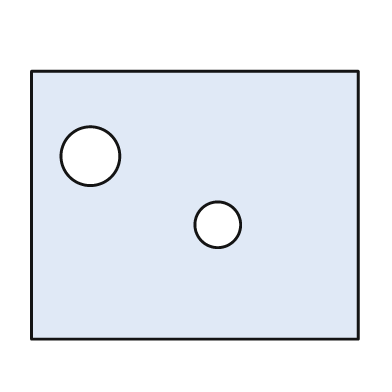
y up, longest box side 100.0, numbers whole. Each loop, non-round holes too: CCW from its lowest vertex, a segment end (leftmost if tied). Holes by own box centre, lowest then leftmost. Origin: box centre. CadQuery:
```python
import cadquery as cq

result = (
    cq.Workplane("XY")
    .moveTo(-50.0, -41.0)
    .lineTo(50.0, -41.0)
    .lineTo(50.0, 41.0)
    .lineTo(-50.0, 41.0)
    .close()
    .moveTo(7.0, -6.0)
    .circle(7.0)
    .moveTo(-32.0, 15.0)
    .circle(9.0)
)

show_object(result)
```